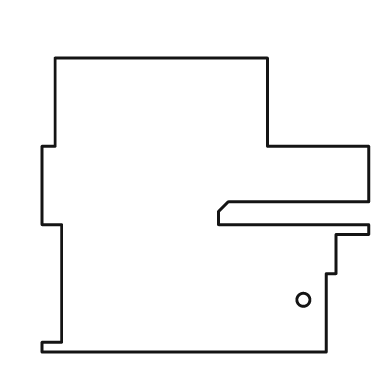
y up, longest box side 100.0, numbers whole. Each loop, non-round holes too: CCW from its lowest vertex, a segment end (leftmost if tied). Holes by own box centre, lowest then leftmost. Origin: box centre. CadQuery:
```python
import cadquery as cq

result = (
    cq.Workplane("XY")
    .moveTo(-50.0, -45.0)
    .lineTo(37.0, -45.0)
    .lineTo(37.0, -21.0)
    .lineTo(40.0, -21.0)
    .lineTo(40.0, -9.0)
    .lineTo(50.0, -9.0)
    .lineTo(50.0, -6.0)
    .lineTo(4.0, -6.0)
    .lineTo(4.0, -2.0)
    .lineTo(7.0, 1.0)
    .lineTo(50.0, 1.0)
    .lineTo(50.0, 18.0)
    .lineTo(19.0, 18.0)
    .lineTo(19.0, 45.0)
    .lineTo(-46.0, 45.0)
    .lineTo(-46.0, 18.0)
    .lineTo(-50.0, 18.0)
    .lineTo(-50.0, -6.0)
    .lineTo(-44.0, -6.0)
    .lineTo(-44.0, -42.0)
    .lineTo(-50.0, -42.0)
    .close()
    .moveTo(30.0, -29.0)
    .circle(2.0)
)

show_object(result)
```